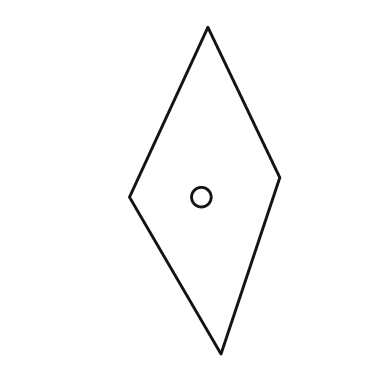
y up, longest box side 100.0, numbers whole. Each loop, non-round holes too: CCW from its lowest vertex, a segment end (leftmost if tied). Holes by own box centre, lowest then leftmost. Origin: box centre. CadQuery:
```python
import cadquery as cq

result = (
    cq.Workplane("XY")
    .moveTo(5.0, -50.0)
    .lineTo(23.0, 4.0)
    .lineTo(1.0, 50.0)
    .lineTo(-23.0, -2.0)
    .close()
    .moveTo(-1.0, -2.0)
    .circle(3.0)
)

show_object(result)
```